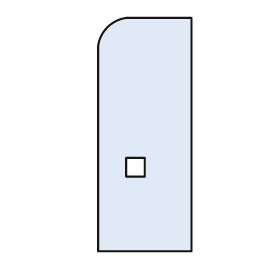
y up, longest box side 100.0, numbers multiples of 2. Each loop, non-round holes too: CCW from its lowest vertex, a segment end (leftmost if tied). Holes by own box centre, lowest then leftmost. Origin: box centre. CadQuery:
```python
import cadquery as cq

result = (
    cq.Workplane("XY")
    .moveTo(-20.0, -50.0)
    .lineTo(20.0, -50.0)
    .lineTo(20.0, 50.0)
    .lineTo(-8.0, 50.0)
    .threePointArc((-16.0, 46.0), (-20.0, 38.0))
    .close()
    .moveTo(-8.0, -18.0)
    .lineTo(0.0, -18.0)
    .lineTo(0.0, -10.0)
    .lineTo(-8.0, -10.0)
    .close()
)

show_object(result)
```